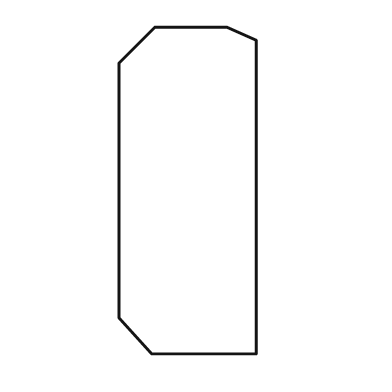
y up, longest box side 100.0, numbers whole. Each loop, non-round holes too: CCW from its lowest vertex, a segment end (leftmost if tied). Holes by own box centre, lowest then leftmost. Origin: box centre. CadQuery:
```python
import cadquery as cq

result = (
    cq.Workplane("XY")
    .moveTo(-11.0, -50.0)
    .lineTo(21.0, -50.0)
    .lineTo(21.0, 46.0)
    .lineTo(12.0, 50.0)
    .lineTo(-10.0, 50.0)
    .lineTo(-21.0, 39.0)
    .lineTo(-21.0, -39.0)
    .close()
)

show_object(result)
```